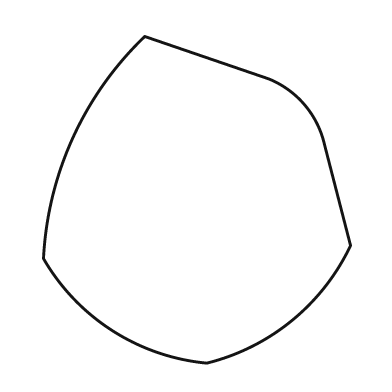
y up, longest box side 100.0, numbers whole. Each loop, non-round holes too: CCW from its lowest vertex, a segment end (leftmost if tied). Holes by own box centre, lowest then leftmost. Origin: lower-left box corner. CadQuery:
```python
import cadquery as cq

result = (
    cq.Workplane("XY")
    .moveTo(50.0, 0.0)
    .threePointArc((76.0, 13.0), (94.0, 36.0))
    .lineTo(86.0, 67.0)
    .threePointArc((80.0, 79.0), (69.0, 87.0))
    .lineTo(31.0, 100.0)
    .threePointArc((9.0, 69.0), (0.0, 32.0))
    .threePointArc((21.0, 10.0), (50.0, 0.0))
    .close()
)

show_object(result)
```